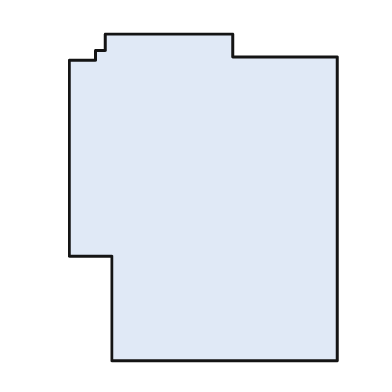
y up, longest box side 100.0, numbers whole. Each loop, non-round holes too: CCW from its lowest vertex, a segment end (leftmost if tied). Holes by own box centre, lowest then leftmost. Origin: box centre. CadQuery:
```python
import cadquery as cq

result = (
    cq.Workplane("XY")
    .moveTo(-28.0, -50.0)
    .lineTo(41.0, -50.0)
    .lineTo(41.0, 43.0)
    .lineTo(9.0, 43.0)
    .lineTo(9.0, 50.0)
    .lineTo(-30.0, 50.0)
    .lineTo(-30.0, 45.0)
    .lineTo(-33.0, 45.0)
    .lineTo(-33.0, 42.0)
    .lineTo(-41.0, 42.0)
    .lineTo(-41.0, -18.0)
    .lineTo(-28.0, -18.0)
    .close()
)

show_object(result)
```